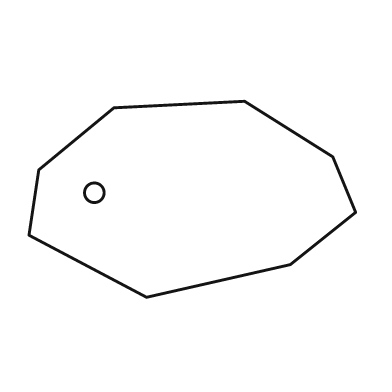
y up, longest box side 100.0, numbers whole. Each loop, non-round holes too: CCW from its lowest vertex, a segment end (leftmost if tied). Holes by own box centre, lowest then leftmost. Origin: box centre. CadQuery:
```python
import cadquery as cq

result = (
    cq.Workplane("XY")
    .moveTo(-14.0, -30.0)
    .lineTo(30.0, -20.0)
    .lineTo(50.0, -4.0)
    .lineTo(43.0, 13.0)
    .lineTo(16.0, 30.0)
    .lineTo(-24.0, 28.0)
    .lineTo(-47.0, 9.0)
    .lineTo(-50.0, -11.0)
    .close()
    .moveTo(-30.0, 2.0)
    .circle(3.0)
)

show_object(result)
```